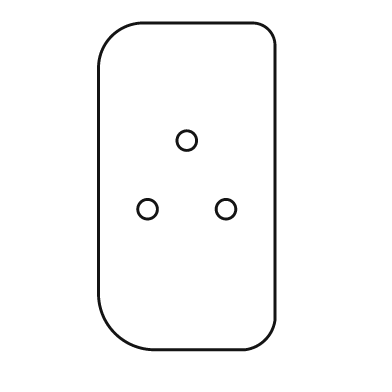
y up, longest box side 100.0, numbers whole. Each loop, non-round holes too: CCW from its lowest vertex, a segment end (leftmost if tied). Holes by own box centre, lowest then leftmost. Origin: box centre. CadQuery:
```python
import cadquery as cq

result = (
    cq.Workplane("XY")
    .moveTo(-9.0, -50.0)
    .lineTo(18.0, -50.0)
    .threePointArc((24.0, -47.0), (27.0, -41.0))
    .lineTo(27.0, 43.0)
    .threePointArc((25.0, 48.0), (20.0, 50.0))
    .lineTo(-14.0, 50.0)
    .threePointArc((-23.0, 46.0), (-27.0, 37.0))
    .lineTo(-27.0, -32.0)
    .threePointArc((-22.0, -45.0), (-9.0, -50.0))
    .close()
    .moveTo(-12.0, -7.0)
    .circle(3.0)
    .moveTo(12.0, -7.0)
    .circle(3.0)
    .moveTo(0.0, 14.0)
    .circle(3.0)
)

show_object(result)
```